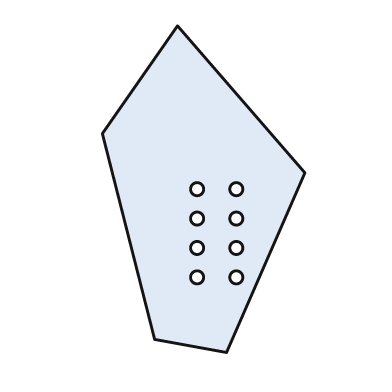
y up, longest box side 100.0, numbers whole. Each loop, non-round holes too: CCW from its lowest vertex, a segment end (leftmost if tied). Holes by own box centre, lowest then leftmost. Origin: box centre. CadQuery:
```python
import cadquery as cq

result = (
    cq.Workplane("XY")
    .moveTo(7.0, -50.0)
    .lineTo(31.0, 5.0)
    .lineTo(-8.0, 50.0)
    .lineTo(-31.0, 17.0)
    .lineTo(-15.0, -46.0)
    .close()
    .moveTo(-2.0, -27.0)
    .circle(2.0)
    .moveTo(10.0, -27.0)
    .circle(2.0)
    .moveTo(-2.0, -18.0)
    .circle(2.0)
    .moveTo(10.0, -18.0)
    .circle(2.0)
    .moveTo(-2.0, -9.0)
    .circle(2.0)
    .moveTo(10.0, -9.0)
    .circle(2.0)
    .moveTo(-2.0, 0.0)
    .circle(2.0)
    .moveTo(10.0, 0.0)
    .circle(2.0)
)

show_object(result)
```